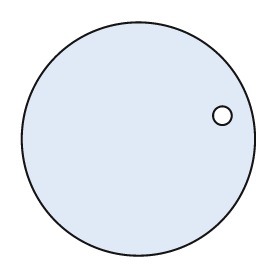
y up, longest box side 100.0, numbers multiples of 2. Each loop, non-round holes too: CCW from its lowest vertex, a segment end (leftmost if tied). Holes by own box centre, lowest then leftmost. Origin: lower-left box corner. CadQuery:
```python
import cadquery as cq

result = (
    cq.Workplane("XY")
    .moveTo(50.0, 50.0)
    .circle(50.0)
    .moveTo(86.0, 60.0)
    .circle(4.0)
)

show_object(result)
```